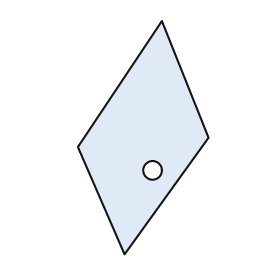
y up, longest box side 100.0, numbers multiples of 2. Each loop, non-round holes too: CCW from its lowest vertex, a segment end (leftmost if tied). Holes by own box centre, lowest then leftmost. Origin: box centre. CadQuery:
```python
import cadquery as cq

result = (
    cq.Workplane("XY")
    .moveTo(-8.0, -50.0)
    .lineTo(28.0, 0.0)
    .lineTo(8.0, 50.0)
    .lineTo(-28.0, -4.0)
    .close()
    .moveTo(4.0, -14.0)
    .circle(4.0)
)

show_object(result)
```